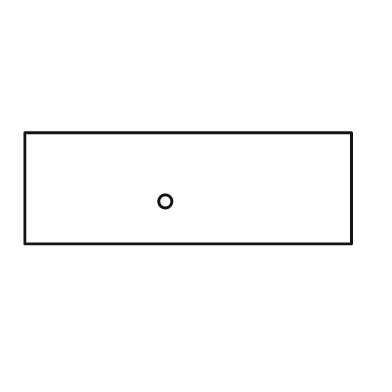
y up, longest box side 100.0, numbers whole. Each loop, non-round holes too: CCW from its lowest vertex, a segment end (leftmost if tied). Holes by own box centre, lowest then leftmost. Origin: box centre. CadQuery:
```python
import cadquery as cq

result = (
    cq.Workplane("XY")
    .moveTo(-50.0, -17.0)
    .lineTo(50.0, -17.0)
    .lineTo(50.0, 17.0)
    .lineTo(-50.0, 17.0)
    .close()
    .moveTo(-7.0, -4.0)
    .circle(2.0)
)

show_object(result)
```